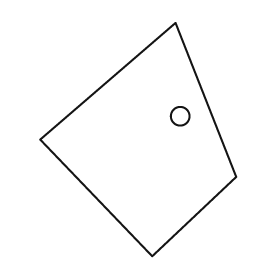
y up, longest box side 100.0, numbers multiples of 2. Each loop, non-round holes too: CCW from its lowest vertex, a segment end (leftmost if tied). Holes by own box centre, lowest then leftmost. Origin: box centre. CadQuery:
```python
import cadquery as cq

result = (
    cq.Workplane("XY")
    .moveTo(6.0, -50.0)
    .lineTo(42.0, -16.0)
    .lineTo(16.0, 50.0)
    .lineTo(-42.0, 0.0)
    .close()
    .moveTo(18.0, 10.0)
    .circle(4.0)
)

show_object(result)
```